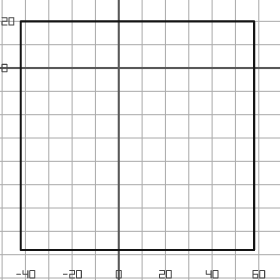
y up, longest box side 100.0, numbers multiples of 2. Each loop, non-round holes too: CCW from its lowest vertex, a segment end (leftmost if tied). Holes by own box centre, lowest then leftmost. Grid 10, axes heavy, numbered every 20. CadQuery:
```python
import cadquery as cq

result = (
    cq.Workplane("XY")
    .moveTo(-42.0, -78.0)
    .lineTo(58.0, -78.0)
    .lineTo(58.0, 20.0)
    .lineTo(-42.0, 20.0)
    .close()
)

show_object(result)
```